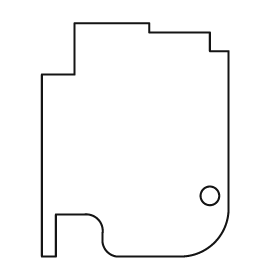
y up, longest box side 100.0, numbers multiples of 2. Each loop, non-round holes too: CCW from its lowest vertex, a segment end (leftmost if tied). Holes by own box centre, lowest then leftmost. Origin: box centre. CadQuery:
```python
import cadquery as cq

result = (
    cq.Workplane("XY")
    .moveTo(-40.0, -50.0)
    .lineTo(-34.0, -50.0)
    .lineTo(-34.0, -32.0)
    .lineTo(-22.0, -32.0)
    .threePointArc((-16.0, -34.0), (-14.0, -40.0))
    .lineTo(-14.0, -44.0)
    .threePointArc((-12.0, -48.0), (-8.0, -50.0))
    .lineTo(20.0, -50.0)
    .threePointArc((34.0, -44.0), (40.0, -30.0))
    .lineTo(40.0, 38.0)
    .lineTo(32.0, 38.0)
    .lineTo(32.0, 46.0)
    .lineTo(6.0, 46.0)
    .lineTo(6.0, 50.0)
    .lineTo(-26.0, 50.0)
    .lineTo(-26.0, 28.0)
    .lineTo(-40.0, 28.0)
    .close()
    .moveTo(32.0, -24.0)
    .circle(4.0)
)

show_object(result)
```